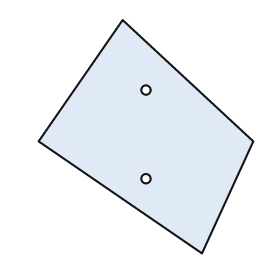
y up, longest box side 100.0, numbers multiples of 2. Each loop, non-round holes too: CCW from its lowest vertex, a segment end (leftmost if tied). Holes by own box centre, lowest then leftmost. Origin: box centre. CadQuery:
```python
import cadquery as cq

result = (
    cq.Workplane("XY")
    .moveTo(24.0, -50.0)
    .lineTo(46.0, -2.0)
    .lineTo(-10.0, 50.0)
    .lineTo(-46.0, -2.0)
    .close()
    .moveTo(0.0, -18.0)
    .circle(2.0)
    .moveTo(0.0, 20.0)
    .circle(2.0)
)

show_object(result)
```